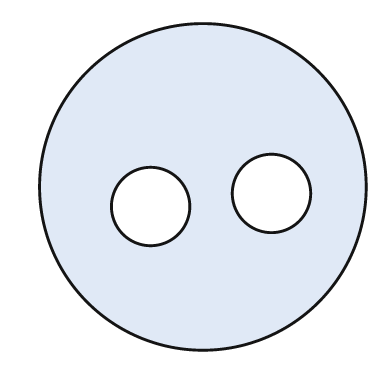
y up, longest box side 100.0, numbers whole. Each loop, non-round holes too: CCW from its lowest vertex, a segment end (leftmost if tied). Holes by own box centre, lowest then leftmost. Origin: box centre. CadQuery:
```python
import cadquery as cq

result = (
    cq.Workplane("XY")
    .moveTo(0.0, 0.0)
    .circle(50.0)
    .moveTo(-16.0, -6.0)
    .circle(12.0)
    .moveTo(21.0, -2.0)
    .circle(12.0)
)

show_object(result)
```